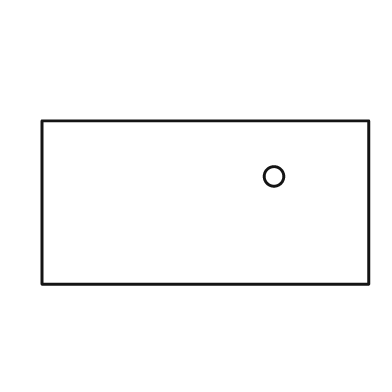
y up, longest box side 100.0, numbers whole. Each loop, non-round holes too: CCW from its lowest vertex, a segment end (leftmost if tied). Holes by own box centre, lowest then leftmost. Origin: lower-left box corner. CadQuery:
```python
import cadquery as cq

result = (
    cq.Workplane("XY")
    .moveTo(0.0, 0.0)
    .lineTo(100.0, 0.0)
    .lineTo(100.0, 50.0)
    .lineTo(0.0, 50.0)
    .close()
    .moveTo(71.0, 33.0)
    .circle(3.0)
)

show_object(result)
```